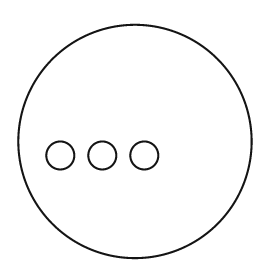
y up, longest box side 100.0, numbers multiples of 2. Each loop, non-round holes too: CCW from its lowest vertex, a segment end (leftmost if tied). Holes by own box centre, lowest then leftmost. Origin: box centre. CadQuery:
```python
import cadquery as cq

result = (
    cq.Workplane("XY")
    .moveTo(0.0, 0.0)
    .circle(50.0)
    .moveTo(-32.0, -6.0)
    .circle(6.0)
    .moveTo(-14.0, -6.0)
    .circle(6.0)
    .moveTo(4.0, -6.0)
    .circle(6.0)
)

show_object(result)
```